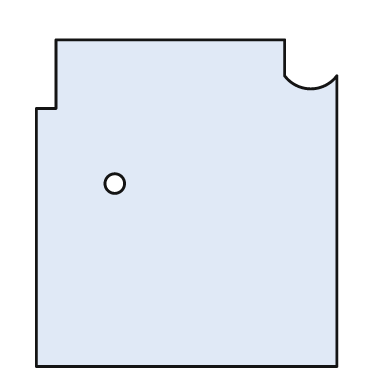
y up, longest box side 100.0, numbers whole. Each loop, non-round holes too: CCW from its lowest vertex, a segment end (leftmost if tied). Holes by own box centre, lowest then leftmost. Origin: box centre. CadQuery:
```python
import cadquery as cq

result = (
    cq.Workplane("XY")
    .moveTo(-46.0, -50.0)
    .lineTo(46.0, -50.0)
    .lineTo(46.0, 39.0)
    .threePointArc((38.0, 35.0), (30.0, 39.0))
    .lineTo(30.0, 50.0)
    .lineTo(-40.0, 50.0)
    .lineTo(-40.0, 29.0)
    .lineTo(-46.0, 29.0)
    .close()
    .moveTo(-22.0, 6.0)
    .circle(3.0)
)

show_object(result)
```